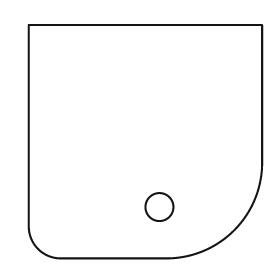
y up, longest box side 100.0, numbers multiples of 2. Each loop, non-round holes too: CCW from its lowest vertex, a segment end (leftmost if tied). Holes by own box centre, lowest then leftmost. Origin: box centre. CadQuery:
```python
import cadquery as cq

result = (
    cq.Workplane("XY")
    .moveTo(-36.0, -50.0)
    .lineTo(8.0, -50.0)
    .threePointArc((38.0, -38.0), (50.0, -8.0))
    .lineTo(50.0, 50.0)
    .lineTo(-50.0, 50.0)
    .lineTo(-50.0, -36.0)
    .threePointArc((-46.0, -46.0), (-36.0, -50.0))
    .close()
    .moveTo(6.0, -28.0)
    .circle(6.0)
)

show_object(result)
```